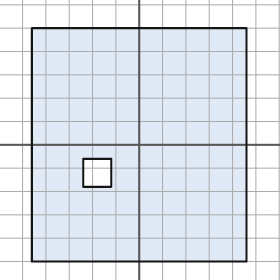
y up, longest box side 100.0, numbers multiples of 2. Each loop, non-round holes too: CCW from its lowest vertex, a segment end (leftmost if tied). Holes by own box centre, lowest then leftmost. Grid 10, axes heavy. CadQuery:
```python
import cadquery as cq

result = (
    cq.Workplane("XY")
    .moveTo(-46.0, -50.0)
    .lineTo(46.0, -50.0)
    .lineTo(46.0, 50.0)
    .lineTo(-46.0, 50.0)
    .close()
    .moveTo(-24.0, -18.0)
    .lineTo(-12.0, -18.0)
    .lineTo(-12.0, -6.0)
    .lineTo(-24.0, -6.0)
    .close()
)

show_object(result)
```